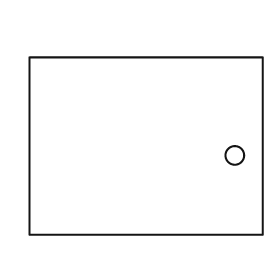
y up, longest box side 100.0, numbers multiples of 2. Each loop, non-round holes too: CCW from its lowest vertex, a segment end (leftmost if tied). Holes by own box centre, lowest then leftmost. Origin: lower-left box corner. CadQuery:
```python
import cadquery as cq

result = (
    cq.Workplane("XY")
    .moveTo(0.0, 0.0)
    .lineTo(100.0, 0.0)
    .lineTo(100.0, 76.0)
    .lineTo(0.0, 76.0)
    .close()
    .moveTo(88.0, 34.0)
    .circle(4.0)
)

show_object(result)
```